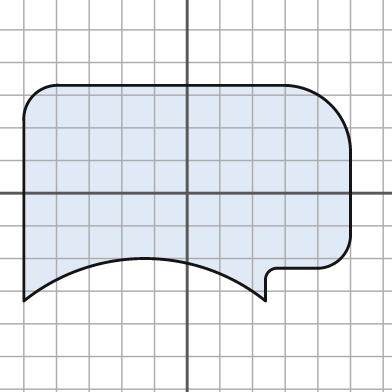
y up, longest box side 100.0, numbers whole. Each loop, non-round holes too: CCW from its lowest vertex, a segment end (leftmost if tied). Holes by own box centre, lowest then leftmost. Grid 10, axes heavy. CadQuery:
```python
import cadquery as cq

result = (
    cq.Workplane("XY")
    .moveTo(-50.0, -33.0)
    .threePointArc((-13.0, -20.0), (24.0, -33.0))
    .lineTo(24.0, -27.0)
    .threePointArc((25.0, -24.0), (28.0, -23.0))
    .lineTo(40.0, -23.0)
    .threePointArc((47.0, -20.0), (50.0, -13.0))
    .lineTo(50.0, 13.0)
    .threePointArc((44.0, 27.0), (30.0, 33.0))
    .lineTo(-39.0, 33.0)
    .threePointArc((-47.0, 30.0), (-50.0, 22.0))
    .close()
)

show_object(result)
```